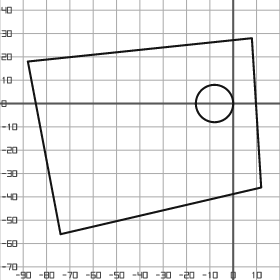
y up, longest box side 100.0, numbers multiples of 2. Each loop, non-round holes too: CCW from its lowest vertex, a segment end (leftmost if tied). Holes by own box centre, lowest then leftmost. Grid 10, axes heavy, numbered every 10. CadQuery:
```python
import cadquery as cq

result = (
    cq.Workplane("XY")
    .moveTo(-74.0, -56.0)
    .lineTo(12.0, -36.0)
    .lineTo(8.0, 28.0)
    .lineTo(-88.0, 18.0)
    .close()
    .moveTo(-8.0, 0.0)
    .circle(8.0)
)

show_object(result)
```